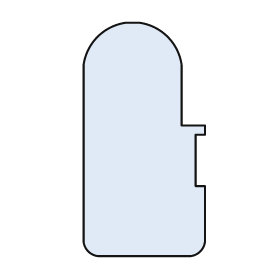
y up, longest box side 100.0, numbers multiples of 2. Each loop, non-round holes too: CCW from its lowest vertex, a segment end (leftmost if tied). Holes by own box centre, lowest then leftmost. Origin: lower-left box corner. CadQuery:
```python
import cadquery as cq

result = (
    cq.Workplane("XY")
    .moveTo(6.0, 0.0)
    .lineTo(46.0, 0.0)
    .threePointArc((50.0, 2.0), (52.0, 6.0))
    .lineTo(52.0, 30.0)
    .lineTo(48.0, 30.0)
    .lineTo(48.0, 52.0)
    .lineTo(52.0, 52.0)
    .lineTo(52.0, 56.0)
    .lineTo(42.0, 56.0)
    .lineTo(42.0, 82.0)
    .threePointArc((36.0, 94.0), (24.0, 100.0))
    .lineTo(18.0, 100.0)
    .threePointArc((6.0, 94.0), (0.0, 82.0))
    .lineTo(0.0, 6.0)
    .threePointArc((2.0, 2.0), (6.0, 0.0))
    .close()
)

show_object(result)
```